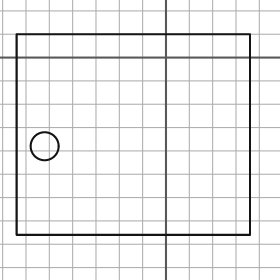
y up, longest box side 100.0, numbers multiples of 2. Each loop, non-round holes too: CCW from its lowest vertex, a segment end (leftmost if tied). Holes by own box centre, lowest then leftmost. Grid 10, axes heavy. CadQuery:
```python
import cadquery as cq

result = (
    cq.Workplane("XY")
    .moveTo(-64.0, -76.0)
    .lineTo(36.0, -76.0)
    .lineTo(36.0, 10.0)
    .lineTo(-64.0, 10.0)
    .close()
    .moveTo(-52.0, -38.0)
    .circle(6.0)
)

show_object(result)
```